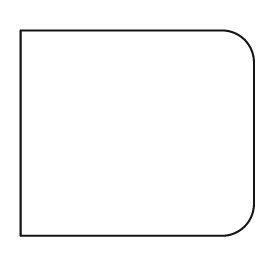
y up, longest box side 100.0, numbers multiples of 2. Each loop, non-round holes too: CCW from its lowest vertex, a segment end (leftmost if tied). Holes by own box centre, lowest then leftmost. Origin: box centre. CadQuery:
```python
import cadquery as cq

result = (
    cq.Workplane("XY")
    .moveTo(-50.0, -44.0)
    .lineTo(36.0, -44.0)
    .threePointArc((46.0, -40.0), (50.0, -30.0))
    .lineTo(50.0, 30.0)
    .threePointArc((46.0, 40.0), (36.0, 44.0))
    .lineTo(-50.0, 44.0)
    .close()
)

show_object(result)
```